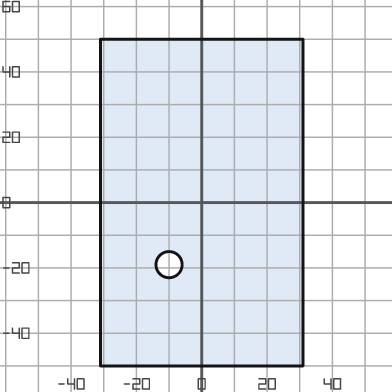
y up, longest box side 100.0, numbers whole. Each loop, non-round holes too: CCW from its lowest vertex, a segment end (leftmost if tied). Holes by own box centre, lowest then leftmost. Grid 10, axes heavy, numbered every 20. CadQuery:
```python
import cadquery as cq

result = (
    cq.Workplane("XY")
    .moveTo(-31.0, -50.0)
    .lineTo(31.0, -50.0)
    .lineTo(31.0, 50.0)
    .lineTo(-31.0, 50.0)
    .close()
    .moveTo(-10.0, -19.0)
    .circle(4.0)
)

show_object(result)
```